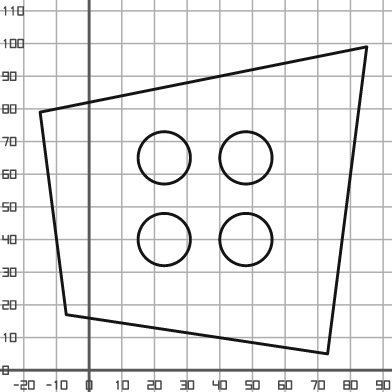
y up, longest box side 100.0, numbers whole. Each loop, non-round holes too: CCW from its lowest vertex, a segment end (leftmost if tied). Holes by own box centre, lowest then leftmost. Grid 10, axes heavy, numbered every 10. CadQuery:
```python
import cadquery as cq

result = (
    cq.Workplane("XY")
    .moveTo(73.0, 5.0)
    .lineTo(85.0, 99.0)
    .lineTo(-15.0, 79.0)
    .lineTo(-7.0, 17.0)
    .close()
    .moveTo(23.0, 40.0)
    .circle(8.0)
    .moveTo(48.0, 40.0)
    .circle(8.0)
    .moveTo(23.0, 65.0)
    .circle(8.0)
    .moveTo(48.0, 65.0)
    .circle(8.0)
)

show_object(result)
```